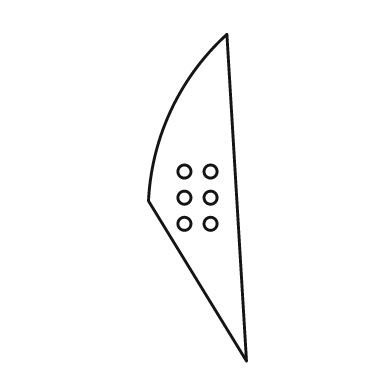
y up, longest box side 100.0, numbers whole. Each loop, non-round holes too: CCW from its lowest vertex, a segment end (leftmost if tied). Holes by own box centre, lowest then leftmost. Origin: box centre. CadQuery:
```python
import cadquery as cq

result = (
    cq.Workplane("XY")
    .moveTo(15.0, -50.0)
    .lineTo(9.0, 50.0)
    .threePointArc((-8.0, 27.0), (-15.0, -1.0))
    .close()
    .moveTo(-4.0, -8.0)
    .circle(2.0)
    .moveTo(4.0, -8.0)
    .circle(2.0)
    .moveTo(-4.0, 0.0)
    .circle(2.0)
    .moveTo(4.0, 0.0)
    .circle(2.0)
    .moveTo(-4.0, 8.0)
    .circle(2.0)
    .moveTo(4.0, 8.0)
    .circle(2.0)
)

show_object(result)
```